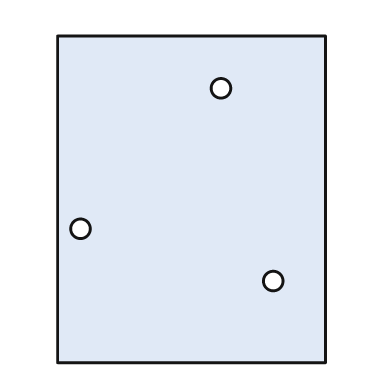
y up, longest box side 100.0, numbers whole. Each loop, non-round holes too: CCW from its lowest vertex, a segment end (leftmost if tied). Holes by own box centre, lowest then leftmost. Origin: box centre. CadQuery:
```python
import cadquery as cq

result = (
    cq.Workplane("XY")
    .moveTo(-41.0, -50.0)
    .lineTo(41.0, -50.0)
    .lineTo(41.0, 50.0)
    .lineTo(-41.0, 50.0)
    .close()
    .moveTo(25.0, -25.0)
    .circle(3.0)
    .moveTo(-34.0, -9.0)
    .circle(3.0)
    .moveTo(9.0, 34.0)
    .circle(3.0)
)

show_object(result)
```